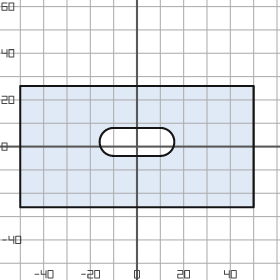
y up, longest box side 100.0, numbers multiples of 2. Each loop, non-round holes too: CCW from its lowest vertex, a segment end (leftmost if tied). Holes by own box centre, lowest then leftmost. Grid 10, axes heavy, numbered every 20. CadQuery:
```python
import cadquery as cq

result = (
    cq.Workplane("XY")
    .moveTo(-50.0, -26.0)
    .lineTo(50.0, -26.0)
    .lineTo(50.0, 26.0)
    .lineTo(-50.0, 26.0)
    .close()
    .moveTo(-10.0, -4.0)
    .lineTo(10.0, -4.0)
    .threePointArc((16.0, 2.0), (10.0, 8.0))
    .lineTo(-10.0, 8.0)
    .threePointArc((-16.0, 2.0), (-10.0, -4.0))
    .close()
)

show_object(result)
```